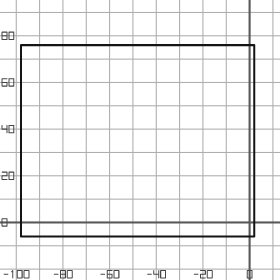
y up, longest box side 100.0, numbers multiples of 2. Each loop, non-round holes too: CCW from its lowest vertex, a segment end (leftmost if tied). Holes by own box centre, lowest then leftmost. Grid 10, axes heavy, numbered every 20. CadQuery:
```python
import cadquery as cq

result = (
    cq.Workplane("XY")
    .moveTo(-98.0, -6.0)
    .lineTo(2.0, -6.0)
    .lineTo(2.0, 76.0)
    .lineTo(-98.0, 76.0)
    .close()
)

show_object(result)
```